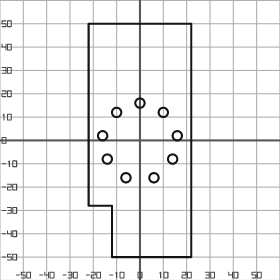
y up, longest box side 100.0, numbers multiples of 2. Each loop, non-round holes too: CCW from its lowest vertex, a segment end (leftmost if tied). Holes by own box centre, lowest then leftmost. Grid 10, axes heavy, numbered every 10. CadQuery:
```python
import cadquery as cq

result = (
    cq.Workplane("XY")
    .moveTo(-12.0, -50.0)
    .lineTo(22.0, -50.0)
    .lineTo(22.0, 50.0)
    .lineTo(-22.0, 50.0)
    .lineTo(-22.0, -28.0)
    .lineTo(-12.0, -28.0)
    .close()
    .moveTo(-6.0, -16.0)
    .circle(2.0)
    .moveTo(6.0, -16.0)
    .circle(2.0)
    .moveTo(-14.0, -8.0)
    .circle(2.0)
    .moveTo(14.0, -8.0)
    .circle(2.0)
    .moveTo(-16.0, 2.0)
    .circle(2.0)
    .moveTo(16.0, 2.0)
    .circle(2.0)
    .moveTo(-10.0, 12.0)
    .circle(2.0)
    .moveTo(10.0, 12.0)
    .circle(2.0)
    .moveTo(0.0, 16.0)
    .circle(2.0)
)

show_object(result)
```